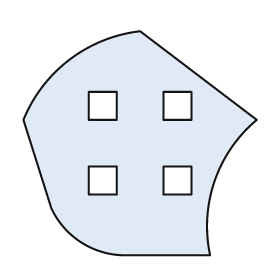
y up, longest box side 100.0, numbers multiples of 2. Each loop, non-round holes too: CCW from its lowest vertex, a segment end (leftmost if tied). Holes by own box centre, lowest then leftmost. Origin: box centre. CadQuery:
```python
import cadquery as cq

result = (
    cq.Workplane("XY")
    .moveTo(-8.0, -48.0)
    .lineTo(30.0, -48.0)
    .threePointArc((32.0, -16.0), (50.0, 10.0))
    .lineTo(0.0, 48.0)
    .threePointArc((-30.0, 36.0), (-50.0, 10.0))
    .lineTo(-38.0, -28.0)
    .threePointArc((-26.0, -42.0), (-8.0, -48.0))
    .close()
    .moveTo(-22.0, -22.0)
    .lineTo(-10.0, -22.0)
    .lineTo(-10.0, -10.0)
    .lineTo(-22.0, -10.0)
    .close()
    .moveTo(10.0, -22.0)
    .lineTo(22.0, -22.0)
    .lineTo(22.0, -10.0)
    .lineTo(10.0, -10.0)
    .close()
    .moveTo(-22.0, 10.0)
    .lineTo(-10.0, 10.0)
    .lineTo(-10.0, 22.0)
    .lineTo(-22.0, 22.0)
    .close()
    .moveTo(10.0, 10.0)
    .lineTo(22.0, 10.0)
    .lineTo(22.0, 22.0)
    .lineTo(10.0, 22.0)
    .close()
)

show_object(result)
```